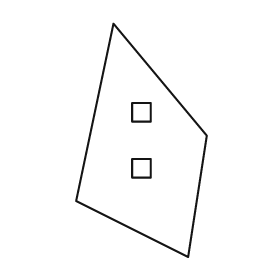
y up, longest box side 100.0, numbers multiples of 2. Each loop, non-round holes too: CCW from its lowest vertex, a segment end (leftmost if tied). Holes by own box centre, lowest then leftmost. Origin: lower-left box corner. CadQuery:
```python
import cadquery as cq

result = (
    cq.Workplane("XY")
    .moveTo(48.0, 0.0)
    .lineTo(56.0, 52.0)
    .lineTo(16.0, 100.0)
    .lineTo(0.0, 24.0)
    .close()
    .moveTo(24.0, 34.0)
    .lineTo(32.0, 34.0)
    .lineTo(32.0, 42.0)
    .lineTo(24.0, 42.0)
    .close()
    .moveTo(24.0, 58.0)
    .lineTo(32.0, 58.0)
    .lineTo(32.0, 66.0)
    .lineTo(24.0, 66.0)
    .close()
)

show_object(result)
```